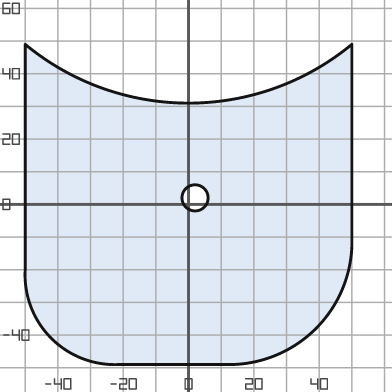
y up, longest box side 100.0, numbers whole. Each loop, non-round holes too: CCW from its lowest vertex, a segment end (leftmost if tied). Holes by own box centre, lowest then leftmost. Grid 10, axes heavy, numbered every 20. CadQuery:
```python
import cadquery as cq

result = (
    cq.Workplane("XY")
    .moveTo(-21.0, -49.0)
    .lineTo(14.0, -49.0)
    .threePointArc((39.0, -38.0), (50.0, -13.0))
    .lineTo(50.0, 49.0)
    .threePointArc((0.0, 31.0), (-50.0, 49.0))
    .lineTo(-50.0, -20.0)
    .threePointArc((-42.0, -41.0), (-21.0, -49.0))
    .close()
    .moveTo(2.0, 2.0)
    .circle(4.0)
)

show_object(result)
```